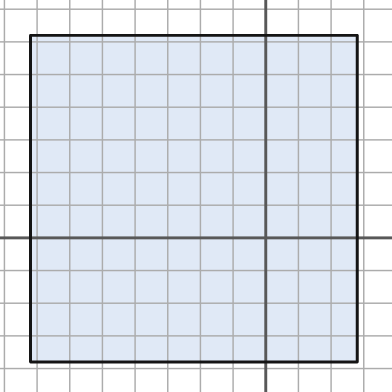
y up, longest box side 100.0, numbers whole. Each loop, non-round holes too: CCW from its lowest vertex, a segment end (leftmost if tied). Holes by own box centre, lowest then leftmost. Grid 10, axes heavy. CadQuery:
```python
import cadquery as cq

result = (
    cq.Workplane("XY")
    .moveTo(-72.0, -38.0)
    .lineTo(28.0, -38.0)
    .lineTo(28.0, 62.0)
    .lineTo(-72.0, 62.0)
    .close()
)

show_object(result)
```